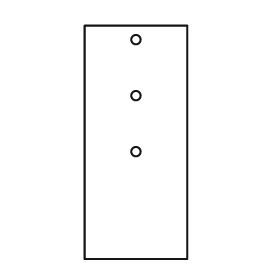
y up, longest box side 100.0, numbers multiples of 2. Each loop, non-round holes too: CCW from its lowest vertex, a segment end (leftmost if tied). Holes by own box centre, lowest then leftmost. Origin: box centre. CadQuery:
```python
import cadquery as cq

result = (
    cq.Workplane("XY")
    .moveTo(-22.0, -50.0)
    .lineTo(22.0, -50.0)
    .lineTo(22.0, 50.0)
    .lineTo(-22.0, 50.0)
    .close()
    .moveTo(0.0, -4.0)
    .circle(2.0)
    .moveTo(0.0, 20.0)
    .circle(2.0)
    .moveTo(0.0, 44.0)
    .circle(2.0)
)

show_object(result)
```